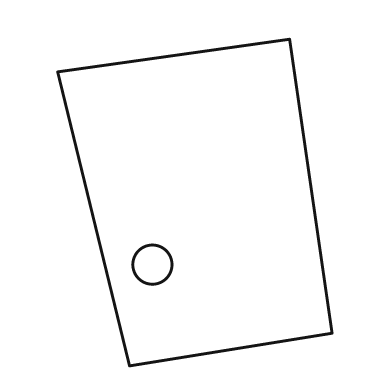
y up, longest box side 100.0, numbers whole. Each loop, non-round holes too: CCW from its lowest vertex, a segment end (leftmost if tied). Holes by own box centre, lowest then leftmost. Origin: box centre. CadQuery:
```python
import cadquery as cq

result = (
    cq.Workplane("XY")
    .moveTo(-20.0, -50.0)
    .lineTo(42.0, -40.0)
    .lineTo(29.0, 50.0)
    .lineTo(-42.0, 40.0)
    .close()
    .moveTo(-13.0, -19.0)
    .circle(6.0)
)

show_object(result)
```